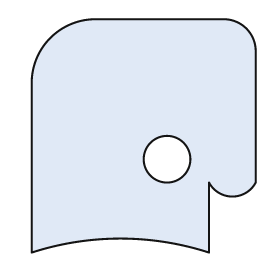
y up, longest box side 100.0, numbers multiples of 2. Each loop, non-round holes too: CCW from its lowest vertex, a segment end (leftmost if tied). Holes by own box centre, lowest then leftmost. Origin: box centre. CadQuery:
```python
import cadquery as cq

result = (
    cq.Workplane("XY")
    .moveTo(-48.0, -50.0)
    .threePointArc((-10.0, -44.0), (28.0, -50.0))
    .lineTo(28.0, -20.0)
    .threePointArc((38.0, -26.0), (48.0, -20.0))
    .lineTo(48.0, 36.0)
    .threePointArc((44.0, 46.0), (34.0, 50.0))
    .lineTo(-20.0, 50.0)
    .threePointArc((-40.0, 42.0), (-48.0, 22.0))
    .close()
    .moveTo(10.0, -10.0)
    .circle(10.0)
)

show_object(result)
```